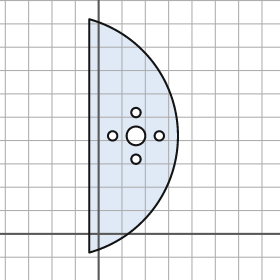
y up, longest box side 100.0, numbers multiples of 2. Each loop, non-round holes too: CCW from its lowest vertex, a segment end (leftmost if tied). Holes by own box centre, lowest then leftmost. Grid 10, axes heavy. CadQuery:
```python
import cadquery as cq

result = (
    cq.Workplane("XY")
    .moveTo(-4.0, -8.0)
    .threePointArc((34.0, 42.0), (-4.0, 92.0))
    .close()
    .moveTo(16.0, 32.0)
    .circle(2.0)
    .moveTo(6.0, 42.0)
    .circle(2.0)
    .moveTo(16.0, 42.0)
    .circle(4.0)
    .moveTo(26.0, 42.0)
    .circle(2.0)
    .moveTo(16.0, 52.0)
    .circle(2.0)
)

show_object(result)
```